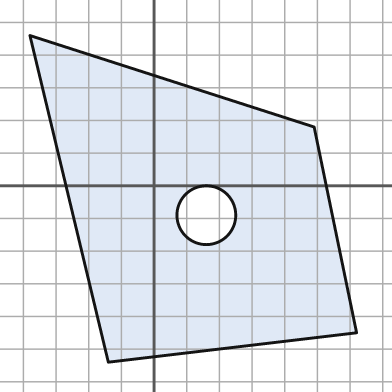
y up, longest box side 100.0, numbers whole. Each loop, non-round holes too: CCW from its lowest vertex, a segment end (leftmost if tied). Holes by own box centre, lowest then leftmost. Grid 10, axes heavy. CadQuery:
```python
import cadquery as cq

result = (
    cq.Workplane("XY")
    .moveTo(-14.0, -54.0)
    .lineTo(62.0, -45.0)
    .lineTo(49.0, 18.0)
    .lineTo(-38.0, 46.0)
    .close()
    .moveTo(16.0, -9.0)
    .circle(9.0)
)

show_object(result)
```